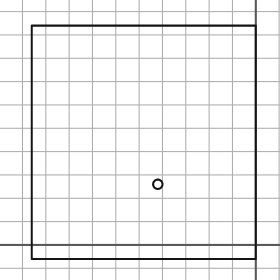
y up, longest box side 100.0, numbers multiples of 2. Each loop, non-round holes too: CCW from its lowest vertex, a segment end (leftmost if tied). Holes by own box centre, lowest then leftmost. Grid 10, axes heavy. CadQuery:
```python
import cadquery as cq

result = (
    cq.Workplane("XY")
    .moveTo(-96.0, -6.0)
    .lineTo(0.0, -6.0)
    .lineTo(0.0, 94.0)
    .lineTo(-96.0, 94.0)
    .close()
    .moveTo(-42.0, 26.0)
    .circle(2.0)
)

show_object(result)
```